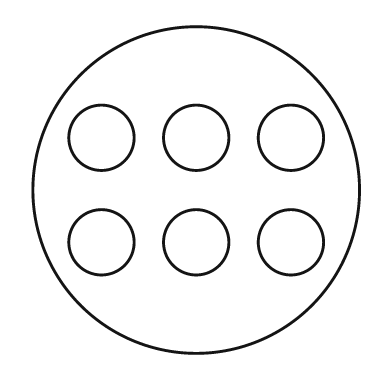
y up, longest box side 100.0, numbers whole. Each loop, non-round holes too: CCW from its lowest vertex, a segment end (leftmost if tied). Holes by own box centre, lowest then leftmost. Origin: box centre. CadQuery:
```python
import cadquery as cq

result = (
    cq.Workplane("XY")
    .moveTo(0.0, 0.0)
    .circle(50.0)
    .moveTo(-29.0, -16.0)
    .circle(10.0)
    .moveTo(0.0, -16.0)
    .circle(10.0)
    .moveTo(29.0, -16.0)
    .circle(10.0)
    .moveTo(-29.0, 16.0)
    .circle(10.0)
    .moveTo(0.0, 16.0)
    .circle(10.0)
    .moveTo(29.0, 16.0)
    .circle(10.0)
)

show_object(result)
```